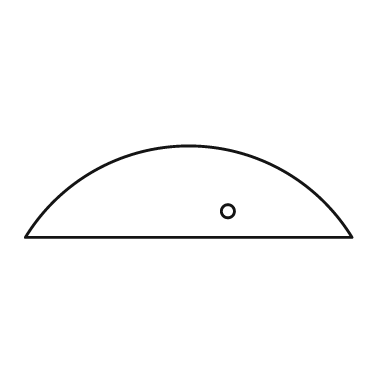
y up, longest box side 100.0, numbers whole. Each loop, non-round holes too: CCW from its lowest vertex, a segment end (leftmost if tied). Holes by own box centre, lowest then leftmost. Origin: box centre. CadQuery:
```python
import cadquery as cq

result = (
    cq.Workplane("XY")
    .moveTo(-50.0, -14.0)
    .lineTo(50.0, -14.0)
    .threePointArc((0.0, 14.0), (-50.0, -14.0))
    .close()
    .moveTo(12.0, -6.0)
    .circle(2.0)
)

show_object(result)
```